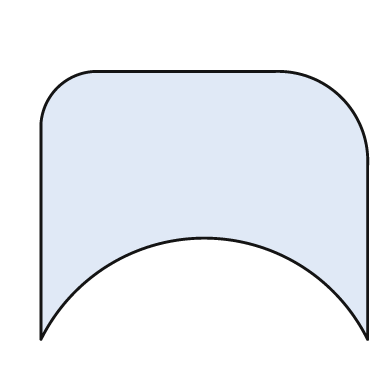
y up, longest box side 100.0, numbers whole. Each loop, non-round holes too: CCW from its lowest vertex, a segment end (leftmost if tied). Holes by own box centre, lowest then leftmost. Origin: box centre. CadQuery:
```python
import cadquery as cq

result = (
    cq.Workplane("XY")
    .moveTo(-50.0, -41.0)
    .threePointArc((0.0, -10.0), (50.0, -41.0))
    .lineTo(50.0, 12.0)
    .threePointArc((42.0, 33.0), (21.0, 41.0))
    .lineTo(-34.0, 41.0)
    .threePointArc((-45.0, 36.0), (-50.0, 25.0))
    .close()
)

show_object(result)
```